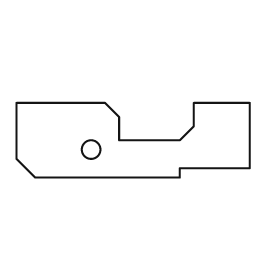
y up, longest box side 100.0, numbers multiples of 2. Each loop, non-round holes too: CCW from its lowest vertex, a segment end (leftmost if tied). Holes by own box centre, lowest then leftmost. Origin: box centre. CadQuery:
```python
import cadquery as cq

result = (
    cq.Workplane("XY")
    .moveTo(-42.0, -16.0)
    .lineTo(20.0, -16.0)
    .lineTo(20.0, -12.0)
    .lineTo(50.0, -12.0)
    .lineTo(50.0, 16.0)
    .lineTo(26.0, 16.0)
    .lineTo(26.0, 6.0)
    .lineTo(20.0, 0.0)
    .lineTo(-6.0, 0.0)
    .lineTo(-6.0, 10.0)
    .lineTo(-12.0, 16.0)
    .lineTo(-50.0, 16.0)
    .lineTo(-50.0, -8.0)
    .close()
    .moveTo(-18.0, -4.0)
    .circle(4.0)
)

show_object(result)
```